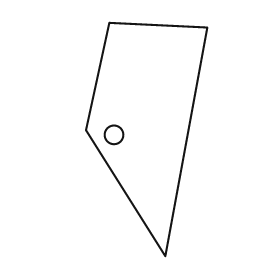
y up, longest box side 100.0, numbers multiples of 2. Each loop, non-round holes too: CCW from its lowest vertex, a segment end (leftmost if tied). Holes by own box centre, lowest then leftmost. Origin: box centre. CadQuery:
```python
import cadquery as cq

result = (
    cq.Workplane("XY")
    .moveTo(8.0, -50.0)
    .lineTo(26.0, 48.0)
    .lineTo(-16.0, 50.0)
    .lineTo(-26.0, 4.0)
    .close()
    .moveTo(-14.0, 2.0)
    .circle(4.0)
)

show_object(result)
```